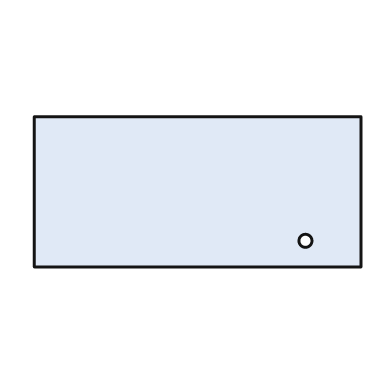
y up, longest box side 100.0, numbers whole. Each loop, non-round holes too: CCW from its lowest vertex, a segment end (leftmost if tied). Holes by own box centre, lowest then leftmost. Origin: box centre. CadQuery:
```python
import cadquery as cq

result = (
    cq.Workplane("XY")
    .moveTo(-50.0, -23.0)
    .lineTo(50.0, -23.0)
    .lineTo(50.0, 23.0)
    .lineTo(-50.0, 23.0)
    .close()
    .moveTo(33.0, -15.0)
    .circle(2.0)
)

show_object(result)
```